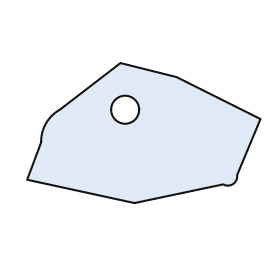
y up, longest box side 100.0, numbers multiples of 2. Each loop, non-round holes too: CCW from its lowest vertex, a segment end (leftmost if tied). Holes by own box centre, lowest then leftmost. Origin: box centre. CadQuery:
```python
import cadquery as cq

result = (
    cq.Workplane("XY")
    .moveTo(-4.0, -30.0)
    .lineTo(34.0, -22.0)
    .threePointArc((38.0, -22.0), (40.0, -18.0))
    .lineTo(50.0, 6.0)
    .lineTo(14.0, 24.0)
    .lineTo(-10.0, 30.0)
    .lineTo(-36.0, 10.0)
    .threePointArc((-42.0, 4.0), (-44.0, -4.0))
    .lineTo(-50.0, -20.0)
    .close()
    .moveTo(-8.0, 10.0)
    .circle(6.0)
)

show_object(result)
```